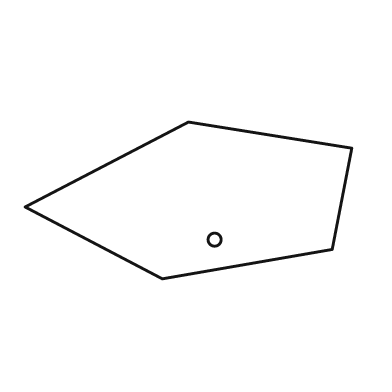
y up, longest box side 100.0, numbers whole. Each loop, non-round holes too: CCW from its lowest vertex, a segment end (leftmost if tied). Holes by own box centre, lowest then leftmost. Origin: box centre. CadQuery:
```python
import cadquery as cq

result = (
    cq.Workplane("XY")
    .moveTo(-8.0, -24.0)
    .lineTo(44.0, -15.0)
    .lineTo(50.0, 16.0)
    .lineTo(0.0, 24.0)
    .lineTo(-50.0, -2.0)
    .close()
    .moveTo(8.0, -12.0)
    .circle(2.0)
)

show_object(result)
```